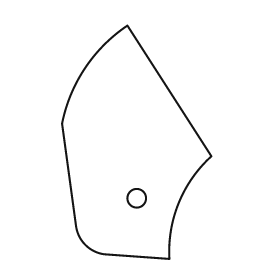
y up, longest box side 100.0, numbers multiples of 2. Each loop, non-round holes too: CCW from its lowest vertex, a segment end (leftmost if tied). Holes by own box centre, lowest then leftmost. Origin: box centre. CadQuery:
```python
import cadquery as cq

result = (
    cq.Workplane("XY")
    .moveTo(14.0, -50.0)
    .threePointArc((18.0, -26.0), (32.0, -6.0))
    .lineTo(-4.0, 50.0)
    .threePointArc((-22.0, 32.0), (-32.0, 8.0))
    .lineTo(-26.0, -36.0)
    .threePointArc((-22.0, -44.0), (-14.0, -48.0))
    .close()
    .moveTo(0.0, -24.0)
    .circle(4.0)
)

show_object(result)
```